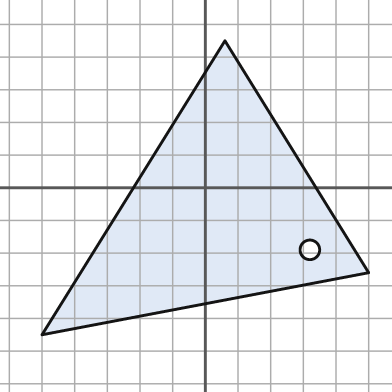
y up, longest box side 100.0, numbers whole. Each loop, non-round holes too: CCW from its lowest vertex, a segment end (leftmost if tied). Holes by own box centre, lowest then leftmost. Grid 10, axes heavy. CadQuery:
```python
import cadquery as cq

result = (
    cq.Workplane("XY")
    .moveTo(-50.0, -45.0)
    .lineTo(50.0, -26.0)
    .lineTo(6.0, 45.0)
    .close()
    .moveTo(32.0, -19.0)
    .circle(3.0)
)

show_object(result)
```